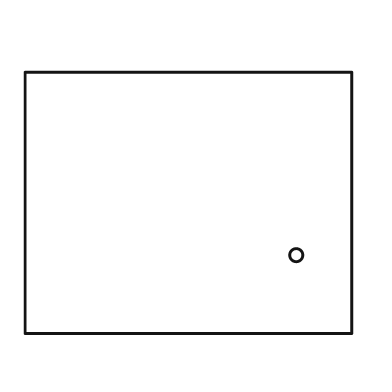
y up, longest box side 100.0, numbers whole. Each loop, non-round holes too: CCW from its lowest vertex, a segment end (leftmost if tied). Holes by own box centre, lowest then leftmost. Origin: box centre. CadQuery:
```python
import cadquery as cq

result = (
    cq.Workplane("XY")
    .moveTo(-50.0, -40.0)
    .lineTo(50.0, -40.0)
    .lineTo(50.0, 40.0)
    .lineTo(-50.0, 40.0)
    .close()
    .moveTo(33.0, -16.0)
    .circle(2.0)
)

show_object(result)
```